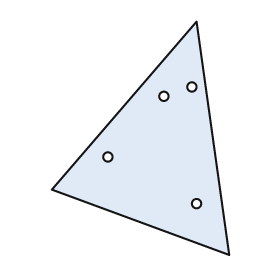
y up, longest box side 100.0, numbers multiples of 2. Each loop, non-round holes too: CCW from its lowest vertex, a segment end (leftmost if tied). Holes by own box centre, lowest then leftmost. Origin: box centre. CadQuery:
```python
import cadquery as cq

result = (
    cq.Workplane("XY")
    .moveTo(38.0, -50.0)
    .lineTo(24.0, 50.0)
    .lineTo(-38.0, -22.0)
    .close()
    .moveTo(24.0, -28.0)
    .circle(2.0)
    .moveTo(-14.0, -8.0)
    .circle(2.0)
    .moveTo(10.0, 18.0)
    .circle(2.0)
    .moveTo(22.0, 22.0)
    .circle(2.0)
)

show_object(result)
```